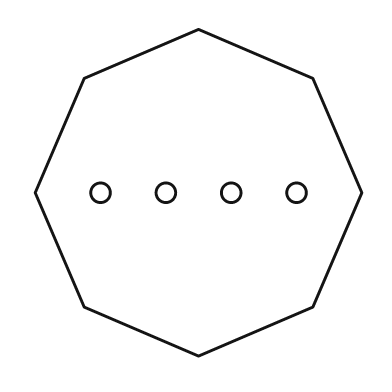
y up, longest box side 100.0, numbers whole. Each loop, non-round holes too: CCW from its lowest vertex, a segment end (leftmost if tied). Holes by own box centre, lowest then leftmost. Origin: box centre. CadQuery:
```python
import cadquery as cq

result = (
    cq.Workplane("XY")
    .moveTo(0.0, -50.0)
    .lineTo(35.0, -35.0)
    .lineTo(50.0, 0.0)
    .lineTo(35.0, 35.0)
    .lineTo(0.0, 50.0)
    .lineTo(-35.0, 35.0)
    .lineTo(-50.0, 0.0)
    .lineTo(-35.0, -35.0)
    .close()
    .moveTo(-30.0, 0.0)
    .circle(3.0)
    .moveTo(-10.0, 0.0)
    .circle(3.0)
    .moveTo(10.0, 0.0)
    .circle(3.0)
    .moveTo(30.0, 0.0)
    .circle(3.0)
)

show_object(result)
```